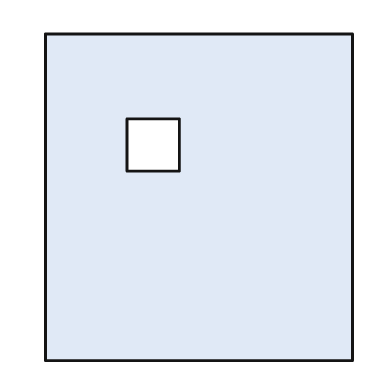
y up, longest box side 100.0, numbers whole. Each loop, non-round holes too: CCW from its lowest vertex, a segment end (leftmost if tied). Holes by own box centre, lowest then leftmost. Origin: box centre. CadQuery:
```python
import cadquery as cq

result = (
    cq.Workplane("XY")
    .moveTo(-47.0, -50.0)
    .lineTo(47.0, -50.0)
    .lineTo(47.0, 50.0)
    .lineTo(-47.0, 50.0)
    .close()
    .moveTo(-22.0, 8.0)
    .lineTo(-6.0, 8.0)
    .lineTo(-6.0, 24.0)
    .lineTo(-22.0, 24.0)
    .close()
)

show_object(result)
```